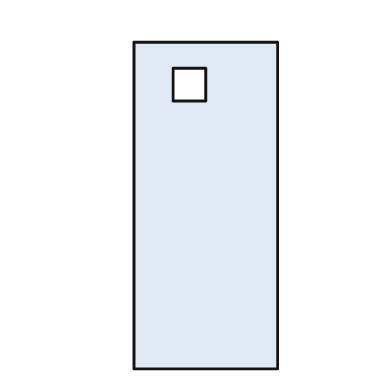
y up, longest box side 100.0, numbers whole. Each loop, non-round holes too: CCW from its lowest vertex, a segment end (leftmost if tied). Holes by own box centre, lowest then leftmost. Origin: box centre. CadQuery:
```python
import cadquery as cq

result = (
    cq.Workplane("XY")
    .moveTo(-22.0, -50.0)
    .lineTo(22.0, -50.0)
    .lineTo(22.0, 50.0)
    .lineTo(-22.0, 50.0)
    .close()
    .moveTo(-10.0, 32.0)
    .lineTo(0.0, 32.0)
    .lineTo(0.0, 42.0)
    .lineTo(-10.0, 42.0)
    .close()
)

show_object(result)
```